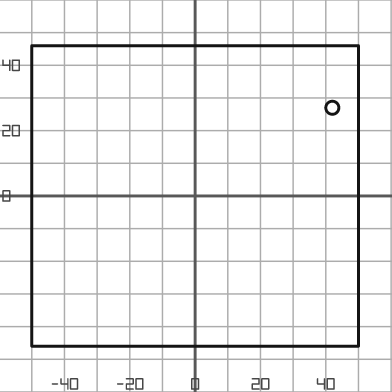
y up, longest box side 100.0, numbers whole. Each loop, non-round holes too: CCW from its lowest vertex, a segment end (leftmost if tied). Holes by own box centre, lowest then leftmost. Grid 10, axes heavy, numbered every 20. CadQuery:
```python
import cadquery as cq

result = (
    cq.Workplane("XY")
    .moveTo(-50.0, -46.0)
    .lineTo(50.0, -46.0)
    .lineTo(50.0, 46.0)
    .lineTo(-50.0, 46.0)
    .close()
    .moveTo(42.0, 27.0)
    .circle(2.0)
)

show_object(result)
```